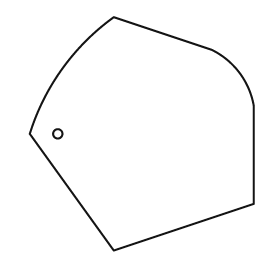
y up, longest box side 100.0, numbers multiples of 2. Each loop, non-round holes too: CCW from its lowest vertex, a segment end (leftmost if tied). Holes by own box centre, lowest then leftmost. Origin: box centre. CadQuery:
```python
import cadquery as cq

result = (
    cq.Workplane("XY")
    .moveTo(-12.0, -50.0)
    .lineTo(48.0, -30.0)
    .lineTo(48.0, 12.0)
    .threePointArc((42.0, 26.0), (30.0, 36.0))
    .lineTo(-12.0, 50.0)
    .threePointArc((-34.0, 28.0), (-48.0, 0.0))
    .close()
    .moveTo(-36.0, 0.0)
    .circle(2.0)
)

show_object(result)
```